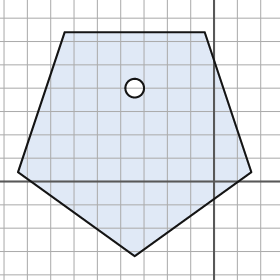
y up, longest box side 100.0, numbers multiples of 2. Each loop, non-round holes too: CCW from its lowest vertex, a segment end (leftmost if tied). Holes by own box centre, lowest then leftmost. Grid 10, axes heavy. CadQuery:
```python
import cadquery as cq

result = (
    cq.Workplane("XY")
    .moveTo(-34.0, -32.0)
    .lineTo(16.0, 4.0)
    .lineTo(-4.0, 64.0)
    .lineTo(-64.0, 64.0)
    .lineTo(-84.0, 4.0)
    .close()
    .moveTo(-34.0, 40.0)
    .circle(4.0)
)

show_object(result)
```